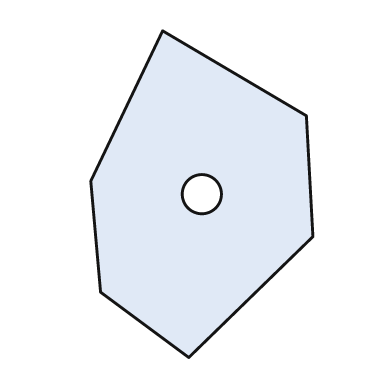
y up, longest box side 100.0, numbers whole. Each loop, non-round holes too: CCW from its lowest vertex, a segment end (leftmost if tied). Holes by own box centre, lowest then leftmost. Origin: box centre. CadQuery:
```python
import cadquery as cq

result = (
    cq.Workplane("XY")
    .moveTo(-4.0, -50.0)
    .lineTo(34.0, -13.0)
    .lineTo(32.0, 24.0)
    .lineTo(-12.0, 50.0)
    .lineTo(-34.0, 4.0)
    .lineTo(-31.0, -30.0)
    .close()
    .moveTo(0.0, 0.0)
    .circle(6.0)
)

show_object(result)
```